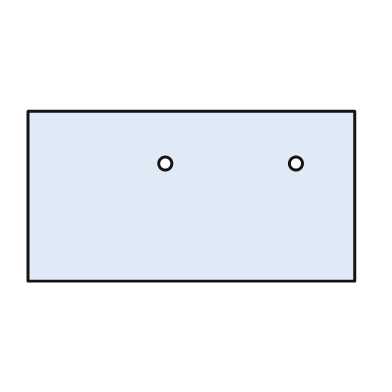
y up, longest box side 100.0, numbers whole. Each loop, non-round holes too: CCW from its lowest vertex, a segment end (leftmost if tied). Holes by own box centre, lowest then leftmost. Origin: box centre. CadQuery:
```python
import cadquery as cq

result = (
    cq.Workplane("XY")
    .moveTo(-50.0, -26.0)
    .lineTo(50.0, -26.0)
    .lineTo(50.0, 26.0)
    .lineTo(-50.0, 26.0)
    .close()
    .moveTo(-8.0, 10.0)
    .circle(2.0)
    .moveTo(32.0, 10.0)
    .circle(2.0)
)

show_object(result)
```